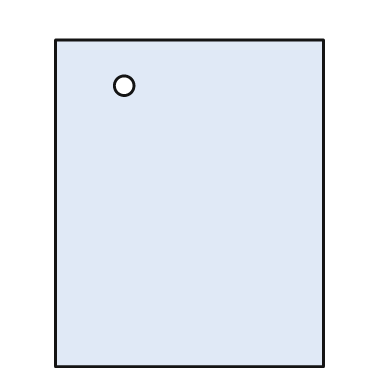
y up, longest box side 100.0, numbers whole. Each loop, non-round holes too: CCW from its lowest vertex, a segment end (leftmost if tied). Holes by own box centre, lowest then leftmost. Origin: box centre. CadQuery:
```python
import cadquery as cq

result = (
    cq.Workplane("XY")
    .moveTo(-41.0, -50.0)
    .lineTo(41.0, -50.0)
    .lineTo(41.0, 50.0)
    .lineTo(-41.0, 50.0)
    .close()
    .moveTo(-20.0, 36.0)
    .circle(3.0)
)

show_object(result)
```